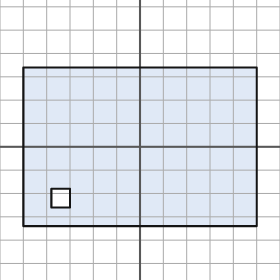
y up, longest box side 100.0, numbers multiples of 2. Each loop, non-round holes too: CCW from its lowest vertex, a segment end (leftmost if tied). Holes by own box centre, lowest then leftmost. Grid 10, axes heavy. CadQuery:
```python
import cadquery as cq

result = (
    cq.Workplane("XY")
    .moveTo(-50.0, -34.0)
    .lineTo(50.0, -34.0)
    .lineTo(50.0, 34.0)
    .lineTo(-50.0, 34.0)
    .close()
    .moveTo(-38.0, -26.0)
    .lineTo(-30.0, -26.0)
    .lineTo(-30.0, -18.0)
    .lineTo(-38.0, -18.0)
    .close()
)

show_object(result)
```